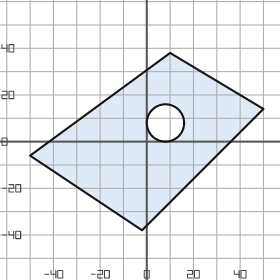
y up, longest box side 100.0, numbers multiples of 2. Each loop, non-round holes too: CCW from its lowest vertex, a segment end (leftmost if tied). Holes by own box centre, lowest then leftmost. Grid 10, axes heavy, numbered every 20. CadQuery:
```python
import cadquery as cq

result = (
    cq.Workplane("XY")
    .moveTo(-2.0, -38.0)
    .lineTo(50.0, 14.0)
    .lineTo(10.0, 38.0)
    .lineTo(-50.0, -6.0)
    .close()
    .moveTo(8.0, 8.0)
    .circle(8.0)
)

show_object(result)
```